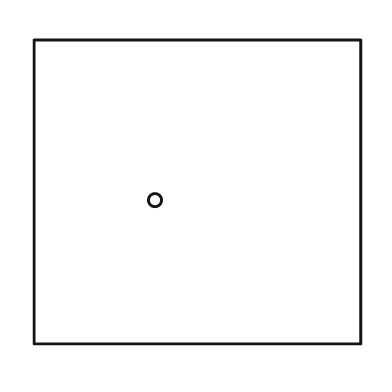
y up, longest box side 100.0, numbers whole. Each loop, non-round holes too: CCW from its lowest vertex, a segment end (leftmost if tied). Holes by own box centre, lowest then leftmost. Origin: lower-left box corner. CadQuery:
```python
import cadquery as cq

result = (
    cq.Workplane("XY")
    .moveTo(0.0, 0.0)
    .lineTo(100.0, 0.0)
    .lineTo(100.0, 93.0)
    .lineTo(0.0, 93.0)
    .close()
    .moveTo(37.0, 44.0)
    .circle(2.0)
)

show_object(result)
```